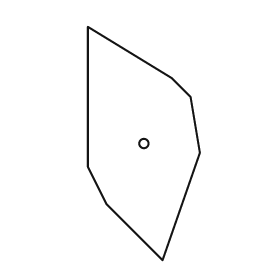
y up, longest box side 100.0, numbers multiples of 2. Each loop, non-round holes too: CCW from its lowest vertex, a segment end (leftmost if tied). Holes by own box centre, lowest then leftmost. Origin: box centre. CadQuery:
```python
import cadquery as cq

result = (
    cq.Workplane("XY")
    .moveTo(8.0, -50.0)
    .lineTo(24.0, -4.0)
    .lineTo(20.0, 20.0)
    .lineTo(12.0, 28.0)
    .lineTo(-24.0, 50.0)
    .lineTo(-24.0, -10.0)
    .lineTo(-16.0, -26.0)
    .close()
    .moveTo(0.0, 0.0)
    .circle(2.0)
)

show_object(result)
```